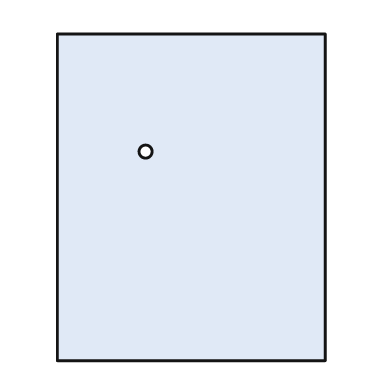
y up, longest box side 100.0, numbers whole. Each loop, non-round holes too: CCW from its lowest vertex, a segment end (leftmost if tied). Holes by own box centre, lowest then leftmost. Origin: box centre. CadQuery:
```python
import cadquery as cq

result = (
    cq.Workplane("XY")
    .moveTo(-41.0, -50.0)
    .lineTo(41.0, -50.0)
    .lineTo(41.0, 50.0)
    .lineTo(-41.0, 50.0)
    .close()
    .moveTo(-14.0, 14.0)
    .circle(2.0)
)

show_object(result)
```